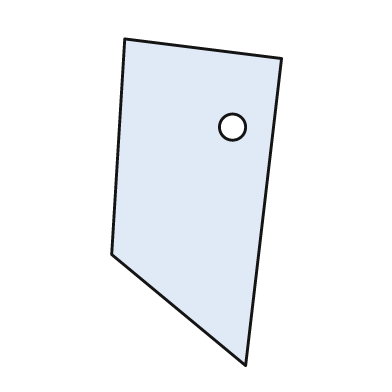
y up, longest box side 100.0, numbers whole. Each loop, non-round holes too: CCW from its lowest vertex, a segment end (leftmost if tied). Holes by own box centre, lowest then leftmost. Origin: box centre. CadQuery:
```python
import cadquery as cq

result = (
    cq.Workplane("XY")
    .moveTo(15.0, -50.0)
    .lineTo(26.0, 44.0)
    .lineTo(-22.0, 50.0)
    .lineTo(-26.0, -16.0)
    .close()
    .moveTo(11.0, 23.0)
    .circle(4.0)
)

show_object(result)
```